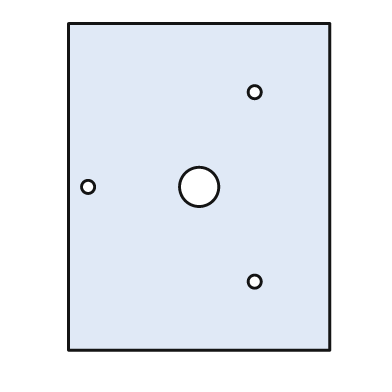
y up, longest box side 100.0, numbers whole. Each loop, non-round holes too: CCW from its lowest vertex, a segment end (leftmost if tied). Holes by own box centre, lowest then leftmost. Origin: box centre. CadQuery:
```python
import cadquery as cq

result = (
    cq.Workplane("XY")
    .moveTo(-40.0, -50.0)
    .lineTo(40.0, -50.0)
    .lineTo(40.0, 50.0)
    .lineTo(-40.0, 50.0)
    .close()
    .moveTo(17.0, -29.0)
    .circle(2.0)
    .moveTo(-34.0, 0.0)
    .circle(2.0)
    .moveTo(0.0, 0.0)
    .circle(6.0)
    .moveTo(17.0, 29.0)
    .circle(2.0)
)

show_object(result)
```